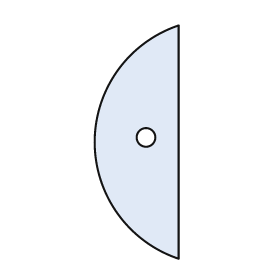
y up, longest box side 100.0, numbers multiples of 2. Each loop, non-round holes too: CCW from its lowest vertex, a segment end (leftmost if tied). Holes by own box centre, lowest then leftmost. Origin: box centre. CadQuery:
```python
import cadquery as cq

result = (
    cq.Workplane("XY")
    .moveTo(18.0, -50.0)
    .lineTo(18.0, 50.0)
    .threePointArc((-18.0, 0.0), (18.0, -50.0))
    .close()
    .moveTo(4.0, 2.0)
    .circle(4.0)
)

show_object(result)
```